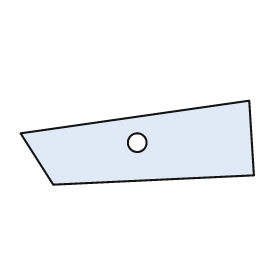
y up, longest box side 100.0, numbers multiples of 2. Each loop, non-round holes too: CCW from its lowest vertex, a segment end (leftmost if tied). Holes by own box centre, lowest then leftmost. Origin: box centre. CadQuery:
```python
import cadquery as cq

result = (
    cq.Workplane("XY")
    .moveTo(-36.0, -18.0)
    .lineTo(50.0, -14.0)
    .lineTo(48.0, 18.0)
    .lineTo(-50.0, 4.0)
    .close()
    .moveTo(0.0, 0.0)
    .circle(4.0)
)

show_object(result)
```